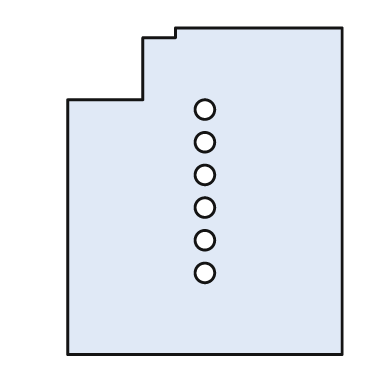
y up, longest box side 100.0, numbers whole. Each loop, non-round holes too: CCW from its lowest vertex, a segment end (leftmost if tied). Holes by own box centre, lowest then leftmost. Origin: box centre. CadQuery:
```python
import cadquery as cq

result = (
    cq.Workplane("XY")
    .moveTo(-42.0, -50.0)
    .lineTo(42.0, -50.0)
    .lineTo(42.0, 50.0)
    .lineTo(-9.0, 50.0)
    .lineTo(-9.0, 47.0)
    .lineTo(-19.0, 47.0)
    .lineTo(-19.0, 28.0)
    .lineTo(-42.0, 28.0)
    .close()
    .moveTo(0.0, -25.0)
    .circle(3.0)
    .moveTo(0.0, -15.0)
    .circle(3.0)
    .moveTo(0.0, -5.0)
    .circle(3.0)
    .moveTo(0.0, 5.0)
    .circle(3.0)
    .moveTo(0.0, 15.0)
    .circle(3.0)
    .moveTo(0.0, 25.0)
    .circle(3.0)
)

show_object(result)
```